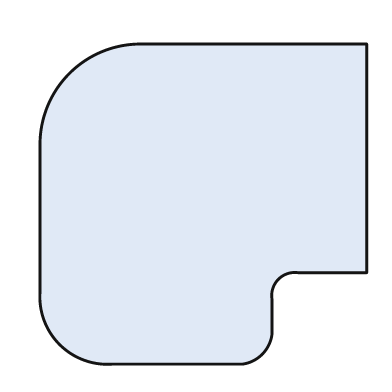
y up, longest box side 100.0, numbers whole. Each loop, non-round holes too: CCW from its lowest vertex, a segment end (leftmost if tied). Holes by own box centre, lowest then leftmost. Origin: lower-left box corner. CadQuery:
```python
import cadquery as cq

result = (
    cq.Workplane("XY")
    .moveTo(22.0, 0.0)
    .lineTo(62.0, 0.0)
    .threePointArc((68.0, 3.0), (71.0, 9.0))
    .lineTo(71.0, 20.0)
    .threePointArc((73.0, 26.0), (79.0, 28.0))
    .lineTo(100.0, 28.0)
    .lineTo(100.0, 98.0)
    .lineTo(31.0, 98.0)
    .threePointArc((9.0, 89.0), (0.0, 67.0))
    .lineTo(0.0, 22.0)
    .threePointArc((6.0, 6.0), (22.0, 0.0))
    .close()
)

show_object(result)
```